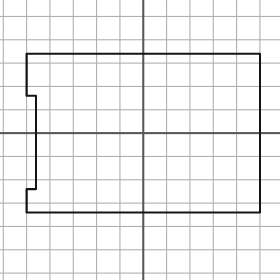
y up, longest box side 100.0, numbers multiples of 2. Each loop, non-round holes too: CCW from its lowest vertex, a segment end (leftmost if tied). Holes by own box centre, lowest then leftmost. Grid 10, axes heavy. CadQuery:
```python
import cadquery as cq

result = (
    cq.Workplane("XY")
    .moveTo(-50.0, -34.0)
    .lineTo(50.0, -34.0)
    .lineTo(50.0, 34.0)
    .lineTo(-50.0, 34.0)
    .lineTo(-50.0, 16.0)
    .lineTo(-46.0, 16.0)
    .lineTo(-46.0, -24.0)
    .lineTo(-50.0, -24.0)
    .close()
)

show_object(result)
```